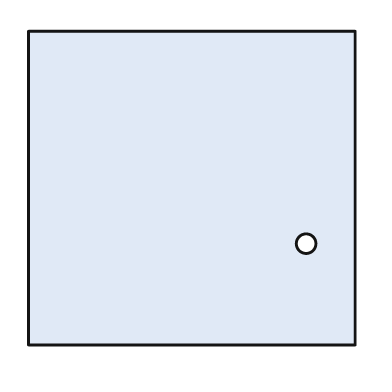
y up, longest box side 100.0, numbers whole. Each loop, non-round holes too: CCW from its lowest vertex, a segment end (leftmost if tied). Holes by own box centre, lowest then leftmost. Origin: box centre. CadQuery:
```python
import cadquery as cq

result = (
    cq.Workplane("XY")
    .moveTo(-50.0, -48.0)
    .lineTo(50.0, -48.0)
    .lineTo(50.0, 48.0)
    .lineTo(-50.0, 48.0)
    .close()
    .moveTo(35.0, -17.0)
    .circle(3.0)
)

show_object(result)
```